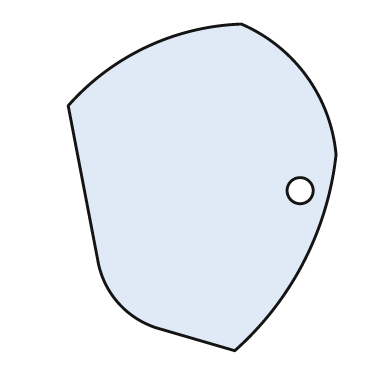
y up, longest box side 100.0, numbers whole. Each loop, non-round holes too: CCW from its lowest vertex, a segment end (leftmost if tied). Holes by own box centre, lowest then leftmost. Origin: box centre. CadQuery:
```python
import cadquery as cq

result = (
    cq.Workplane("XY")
    .moveTo(10.0, -50.0)
    .threePointArc((31.0, -23.0), (41.0, 10.0))
    .threePointArc((32.0, 34.0), (12.0, 50.0))
    .threePointArc((-17.0, 43.0), (-41.0, 25.0))
    .lineTo(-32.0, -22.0)
    .threePointArc((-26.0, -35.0), (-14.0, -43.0))
    .close()
    .moveTo(30.0, -1.0)
    .circle(4.0)
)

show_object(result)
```